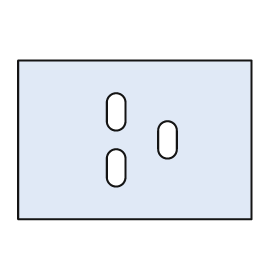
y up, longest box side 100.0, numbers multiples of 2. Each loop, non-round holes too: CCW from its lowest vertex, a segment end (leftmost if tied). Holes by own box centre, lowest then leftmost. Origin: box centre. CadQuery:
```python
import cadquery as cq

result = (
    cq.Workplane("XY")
    .moveTo(-50.0, -34.0)
    .lineTo(50.0, -34.0)
    .lineTo(50.0, 34.0)
    .lineTo(-50.0, 34.0)
    .close()
    .moveTo(-12.0, -16.0)
    .threePointArc((-8.0, -20.0), (-4.0, -16.0))
    .lineTo(-4.0, -8.0)
    .threePointArc((-8.0, -4.0), (-12.0, -8.0))
    .close()
    .moveTo(10.0, -4.0)
    .threePointArc((14.0, -8.0), (18.0, -4.0))
    .lineTo(18.0, 4.0)
    .threePointArc((14.0, 8.0), (10.0, 4.0))
    .close()
    .moveTo(-12.0, 8.0)
    .threePointArc((-8.0, 4.0), (-4.0, 8.0))
    .lineTo(-4.0, 16.0)
    .threePointArc((-8.0, 20.0), (-12.0, 16.0))
    .close()
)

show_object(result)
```